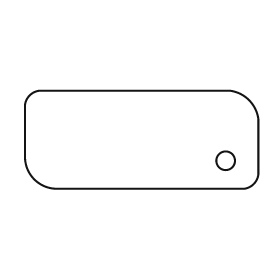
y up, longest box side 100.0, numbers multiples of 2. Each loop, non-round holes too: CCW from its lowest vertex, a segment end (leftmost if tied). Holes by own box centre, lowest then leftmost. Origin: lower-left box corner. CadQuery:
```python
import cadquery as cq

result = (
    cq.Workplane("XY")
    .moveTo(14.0, 0.0)
    .lineTo(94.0, 0.0)
    .threePointArc((98.0, 2.0), (100.0, 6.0))
    .lineTo(100.0, 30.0)
    .threePointArc((96.0, 38.0), (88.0, 42.0))
    .lineTo(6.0, 42.0)
    .threePointArc((2.0, 40.0), (0.0, 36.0))
    .lineTo(0.0, 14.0)
    .threePointArc((4.0, 4.0), (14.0, 0.0))
    .close()
    .moveTo(86.0, 12.0)
    .circle(4.0)
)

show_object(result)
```